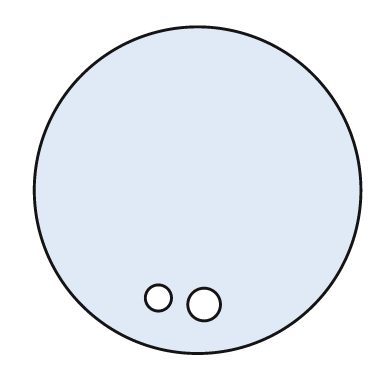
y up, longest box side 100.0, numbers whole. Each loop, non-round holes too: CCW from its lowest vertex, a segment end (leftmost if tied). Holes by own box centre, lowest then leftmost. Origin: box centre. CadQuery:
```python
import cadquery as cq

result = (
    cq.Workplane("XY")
    .moveTo(0.0, 0.0)
    .circle(50.0)
    .moveTo(2.0, -35.0)
    .circle(5.0)
    .moveTo(-12.0, -33.0)
    .circle(4.0)
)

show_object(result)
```